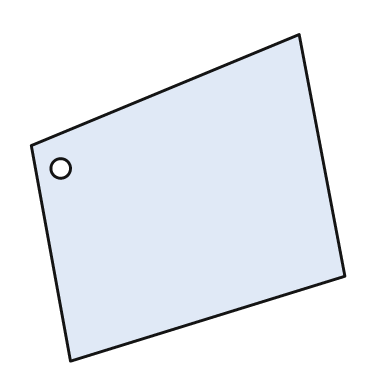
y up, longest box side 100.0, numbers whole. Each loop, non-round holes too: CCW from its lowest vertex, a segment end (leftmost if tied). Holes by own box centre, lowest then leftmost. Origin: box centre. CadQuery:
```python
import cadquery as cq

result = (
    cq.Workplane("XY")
    .moveTo(-36.0, -50.0)
    .lineTo(48.0, -24.0)
    .lineTo(34.0, 50.0)
    .lineTo(-48.0, 16.0)
    .close()
    .moveTo(-39.0, 9.0)
    .circle(3.0)
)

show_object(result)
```